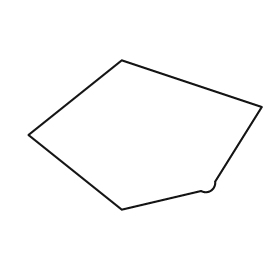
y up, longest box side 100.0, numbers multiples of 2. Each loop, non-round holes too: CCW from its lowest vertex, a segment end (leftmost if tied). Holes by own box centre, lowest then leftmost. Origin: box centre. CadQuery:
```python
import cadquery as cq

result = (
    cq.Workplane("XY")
    .moveTo(-10.0, -32.0)
    .lineTo(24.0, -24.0)
    .threePointArc((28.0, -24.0), (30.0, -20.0))
    .lineTo(50.0, 12.0)
    .lineTo(-10.0, 32.0)
    .lineTo(-50.0, 0.0)
    .close()
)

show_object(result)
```